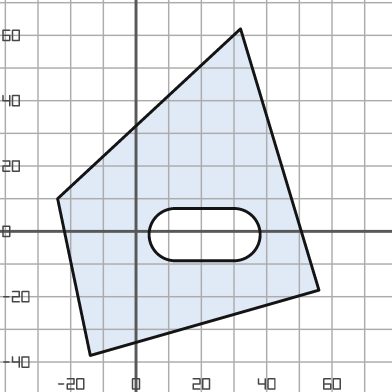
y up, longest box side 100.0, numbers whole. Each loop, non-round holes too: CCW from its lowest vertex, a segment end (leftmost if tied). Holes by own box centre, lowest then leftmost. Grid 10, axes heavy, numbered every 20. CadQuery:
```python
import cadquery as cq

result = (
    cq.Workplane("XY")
    .moveTo(-14.0, -38.0)
    .lineTo(56.0, -18.0)
    .lineTo(32.0, 62.0)
    .lineTo(-24.0, 10.0)
    .close()
    .moveTo(12.0, -9.0)
    .lineTo(30.0, -9.0)
    .threePointArc((38.0, -1.0), (30.0, 7.0))
    .lineTo(12.0, 7.0)
    .threePointArc((4.0, -1.0), (12.0, -9.0))
    .close()
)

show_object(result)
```